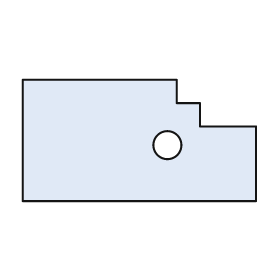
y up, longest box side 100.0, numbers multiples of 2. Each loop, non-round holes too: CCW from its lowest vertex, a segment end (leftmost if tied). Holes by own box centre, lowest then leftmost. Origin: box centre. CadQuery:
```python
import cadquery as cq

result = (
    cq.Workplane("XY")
    .moveTo(-50.0, -26.0)
    .lineTo(50.0, -26.0)
    .lineTo(50.0, 6.0)
    .lineTo(26.0, 6.0)
    .lineTo(26.0, 16.0)
    .lineTo(16.0, 16.0)
    .lineTo(16.0, 26.0)
    .lineTo(-50.0, 26.0)
    .close()
    .moveTo(12.0, -2.0)
    .circle(6.0)
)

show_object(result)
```